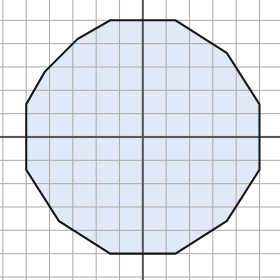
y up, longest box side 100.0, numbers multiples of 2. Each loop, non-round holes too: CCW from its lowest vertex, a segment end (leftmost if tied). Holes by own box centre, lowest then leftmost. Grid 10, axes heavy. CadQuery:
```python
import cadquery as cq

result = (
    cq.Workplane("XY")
    .moveTo(-14.0, -50.0)
    .lineTo(14.0, -50.0)
    .lineTo(36.0, -36.0)
    .lineTo(50.0, -14.0)
    .lineTo(50.0, 14.0)
    .lineTo(36.0, 36.0)
    .lineTo(14.0, 50.0)
    .lineTo(-14.0, 50.0)
    .lineTo(-28.0, 42.0)
    .lineTo(-42.0, 28.0)
    .lineTo(-50.0, 14.0)
    .lineTo(-50.0, -14.0)
    .lineTo(-36.0, -36.0)
    .close()
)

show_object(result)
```